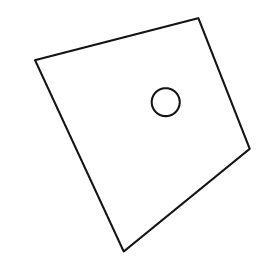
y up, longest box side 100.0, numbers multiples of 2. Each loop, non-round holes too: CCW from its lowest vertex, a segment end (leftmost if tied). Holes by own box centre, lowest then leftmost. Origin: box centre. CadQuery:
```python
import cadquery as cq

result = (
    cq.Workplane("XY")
    .moveTo(-8.0, -50.0)
    .lineTo(46.0, -6.0)
    .lineTo(24.0, 50.0)
    .lineTo(-46.0, 32.0)
    .close()
    .moveTo(10.0, 14.0)
    .circle(6.0)
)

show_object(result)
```